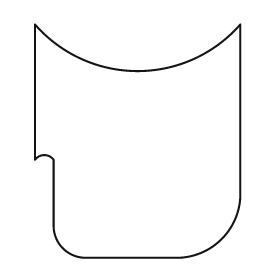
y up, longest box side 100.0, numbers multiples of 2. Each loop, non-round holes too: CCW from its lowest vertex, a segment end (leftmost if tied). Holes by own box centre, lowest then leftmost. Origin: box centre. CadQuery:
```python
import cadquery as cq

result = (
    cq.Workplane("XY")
    .moveTo(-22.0, -50.0)
    .lineTo(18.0, -50.0)
    .threePointArc((36.0, -42.0), (44.0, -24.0))
    .lineTo(44.0, 50.0)
    .threePointArc((0.0, 30.0), (-44.0, 50.0))
    .lineTo(-44.0, -8.0)
    .threePointArc((-40.0, -6.0), (-36.0, -8.0))
    .lineTo(-36.0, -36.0)
    .threePointArc((-32.0, -46.0), (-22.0, -50.0))
    .close()
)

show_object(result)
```